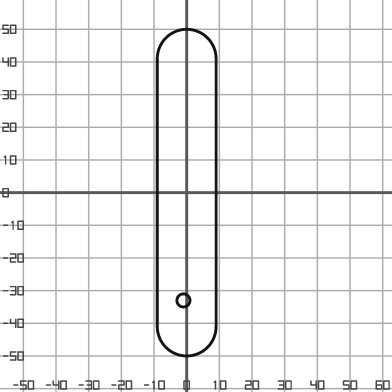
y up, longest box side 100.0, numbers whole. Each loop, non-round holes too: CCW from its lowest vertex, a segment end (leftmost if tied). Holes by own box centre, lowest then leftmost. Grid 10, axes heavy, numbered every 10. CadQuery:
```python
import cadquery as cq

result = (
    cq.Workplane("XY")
    .moveTo(-9.0, -41.0)
    .threePointArc((0.0, -50.0), (9.0, -41.0))
    .lineTo(9.0, 41.0)
    .threePointArc((0.0, 50.0), (-9.0, 41.0))
    .close()
    .moveTo(-1.0, -33.0)
    .circle(2.0)
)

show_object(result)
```